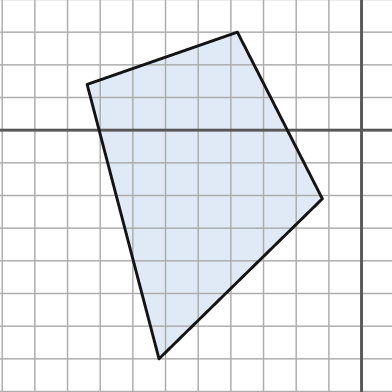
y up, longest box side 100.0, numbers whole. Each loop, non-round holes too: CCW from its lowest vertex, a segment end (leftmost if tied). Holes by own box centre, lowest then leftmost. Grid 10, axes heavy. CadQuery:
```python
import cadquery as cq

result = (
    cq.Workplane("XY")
    .moveTo(-62.0, -70.0)
    .lineTo(-12.0, -21.0)
    .lineTo(-38.0, 30.0)
    .lineTo(-84.0, 14.0)
    .close()
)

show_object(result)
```